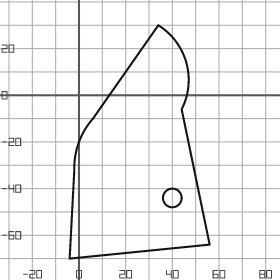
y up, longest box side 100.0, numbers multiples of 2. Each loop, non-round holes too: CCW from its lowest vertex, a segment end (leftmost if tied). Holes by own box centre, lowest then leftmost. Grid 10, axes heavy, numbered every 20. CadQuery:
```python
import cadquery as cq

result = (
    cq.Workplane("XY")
    .moveTo(-4.0, -70.0)
    .lineTo(56.0, -64.0)
    .lineTo(44.0, -6.0)
    .threePointArc((46.0, 14.0), (34.0, 30.0))
    .lineTo(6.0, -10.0)
    .threePointArc((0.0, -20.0), (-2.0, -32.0))
    .close()
    .moveTo(40.0, -44.0)
    .circle(4.0)
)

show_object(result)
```